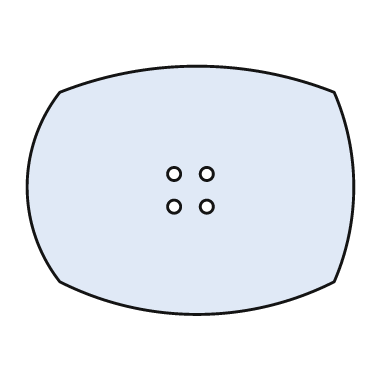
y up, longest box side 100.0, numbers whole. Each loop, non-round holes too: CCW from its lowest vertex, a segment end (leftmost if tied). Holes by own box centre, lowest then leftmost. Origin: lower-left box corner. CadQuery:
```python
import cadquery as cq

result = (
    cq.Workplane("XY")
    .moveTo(10.0, 10.0)
    .threePointArc((52.0, 0.0), (94.0, 10.0))
    .threePointArc((100.0, 39.0), (94.0, 68.0))
    .threePointArc((52.0, 76.0), (10.0, 68.0))
    .threePointArc((0.0, 39.0), (10.0, 10.0))
    .close()
    .moveTo(45.0, 33.0)
    .circle(2.0)
    .moveTo(55.0, 33.0)
    .circle(2.0)
    .moveTo(45.0, 43.0)
    .circle(2.0)
    .moveTo(55.0, 43.0)
    .circle(2.0)
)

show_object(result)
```